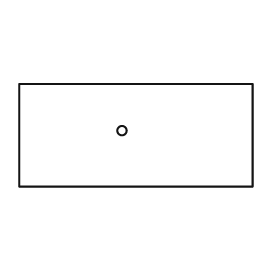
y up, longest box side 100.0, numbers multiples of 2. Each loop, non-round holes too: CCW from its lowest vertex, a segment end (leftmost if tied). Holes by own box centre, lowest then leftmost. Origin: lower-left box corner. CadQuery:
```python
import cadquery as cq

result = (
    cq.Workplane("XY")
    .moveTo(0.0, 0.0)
    .lineTo(100.0, 0.0)
    .lineTo(100.0, 44.0)
    .lineTo(0.0, 44.0)
    .close()
    .moveTo(44.0, 24.0)
    .circle(2.0)
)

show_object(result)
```